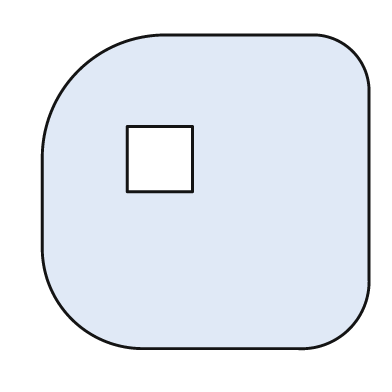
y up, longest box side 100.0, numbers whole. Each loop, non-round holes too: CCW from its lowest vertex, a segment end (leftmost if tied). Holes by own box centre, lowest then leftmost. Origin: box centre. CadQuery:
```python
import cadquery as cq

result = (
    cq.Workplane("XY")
    .moveTo(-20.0, -48.0)
    .lineTo(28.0, -48.0)
    .threePointArc((44.0, -42.0), (50.0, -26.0))
    .lineTo(50.0, 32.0)
    .threePointArc((45.0, 43.0), (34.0, 48.0))
    .lineTo(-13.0, 48.0)
    .threePointArc((-39.0, 37.0), (-50.0, 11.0))
    .lineTo(-50.0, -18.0)
    .threePointArc((-41.0, -39.0), (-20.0, -48.0))
    .close()
    .moveTo(-24.0, 0.0)
    .lineTo(-4.0, 0.0)
    .lineTo(-4.0, 20.0)
    .lineTo(-24.0, 20.0)
    .close()
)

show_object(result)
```